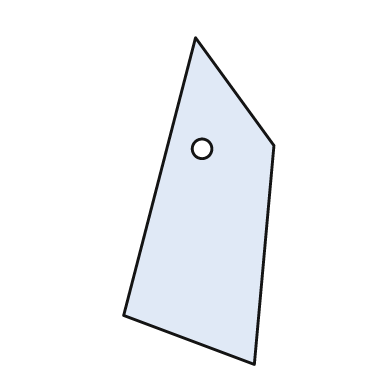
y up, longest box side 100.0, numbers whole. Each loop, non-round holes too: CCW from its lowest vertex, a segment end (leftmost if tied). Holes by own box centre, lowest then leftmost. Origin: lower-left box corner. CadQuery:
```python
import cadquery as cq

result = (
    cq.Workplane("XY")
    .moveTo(40.0, 0.0)
    .lineTo(46.0, 67.0)
    .lineTo(22.0, 100.0)
    .lineTo(0.0, 15.0)
    .close()
    .moveTo(24.0, 66.0)
    .circle(3.0)
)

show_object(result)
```